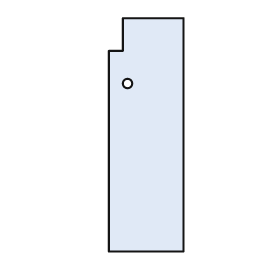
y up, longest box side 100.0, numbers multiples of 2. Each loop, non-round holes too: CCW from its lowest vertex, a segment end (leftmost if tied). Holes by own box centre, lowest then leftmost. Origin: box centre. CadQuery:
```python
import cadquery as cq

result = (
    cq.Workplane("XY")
    .moveTo(-16.0, -50.0)
    .lineTo(16.0, -50.0)
    .lineTo(16.0, 50.0)
    .lineTo(-10.0, 50.0)
    .lineTo(-10.0, 36.0)
    .lineTo(-16.0, 36.0)
    .close()
    .moveTo(-8.0, 22.0)
    .circle(2.0)
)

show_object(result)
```